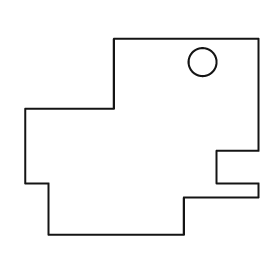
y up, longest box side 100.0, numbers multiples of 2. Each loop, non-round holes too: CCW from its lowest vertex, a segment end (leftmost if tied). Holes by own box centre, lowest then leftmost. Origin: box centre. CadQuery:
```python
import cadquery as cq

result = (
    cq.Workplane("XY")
    .moveTo(-40.0, -42.0)
    .lineTo(18.0, -42.0)
    .lineTo(18.0, -26.0)
    .lineTo(50.0, -26.0)
    .lineTo(50.0, -20.0)
    .lineTo(32.0, -20.0)
    .lineTo(32.0, -6.0)
    .lineTo(50.0, -6.0)
    .lineTo(50.0, 42.0)
    .lineTo(-12.0, 42.0)
    .lineTo(-12.0, 12.0)
    .lineTo(-50.0, 12.0)
    .lineTo(-50.0, -20.0)
    .lineTo(-40.0, -20.0)
    .close()
    .moveTo(26.0, 32.0)
    .circle(6.0)
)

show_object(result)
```